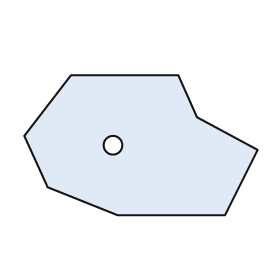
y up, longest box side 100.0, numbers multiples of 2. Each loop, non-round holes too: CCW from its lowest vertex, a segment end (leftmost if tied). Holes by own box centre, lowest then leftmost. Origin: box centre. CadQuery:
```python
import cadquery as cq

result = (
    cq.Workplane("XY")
    .moveTo(-10.0, -30.0)
    .lineTo(36.0, -30.0)
    .lineTo(50.0, -2.0)
    .lineTo(24.0, 12.0)
    .lineTo(16.0, 30.0)
    .lineTo(-30.0, 30.0)
    .lineTo(-50.0, 4.0)
    .lineTo(-40.0, -18.0)
    .close()
    .moveTo(-12.0, 0.0)
    .circle(4.0)
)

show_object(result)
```